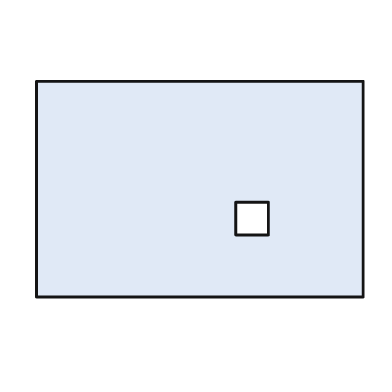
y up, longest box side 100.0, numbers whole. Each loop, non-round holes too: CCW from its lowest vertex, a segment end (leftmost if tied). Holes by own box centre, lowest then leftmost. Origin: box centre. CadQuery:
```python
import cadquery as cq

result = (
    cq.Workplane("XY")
    .moveTo(-50.0, -33.0)
    .lineTo(50.0, -33.0)
    .lineTo(50.0, 33.0)
    .lineTo(-50.0, 33.0)
    .close()
    .moveTo(11.0, -14.0)
    .lineTo(21.0, -14.0)
    .lineTo(21.0, -4.0)
    .lineTo(11.0, -4.0)
    .close()
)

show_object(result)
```